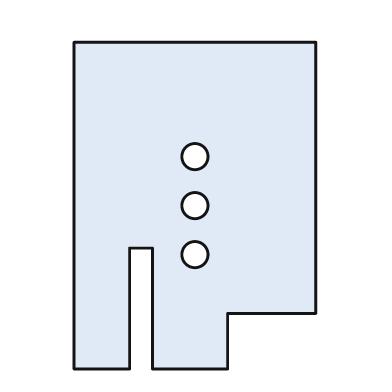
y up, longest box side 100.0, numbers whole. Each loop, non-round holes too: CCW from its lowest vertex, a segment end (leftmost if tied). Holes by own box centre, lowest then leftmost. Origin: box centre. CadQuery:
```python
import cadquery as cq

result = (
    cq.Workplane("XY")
    .moveTo(-37.0, -50.0)
    .lineTo(-20.0, -50.0)
    .lineTo(-20.0, -13.0)
    .lineTo(-13.0, -13.0)
    .lineTo(-13.0, -50.0)
    .lineTo(10.0, -50.0)
    .lineTo(10.0, -33.0)
    .lineTo(37.0, -33.0)
    .lineTo(37.0, 50.0)
    .lineTo(-37.0, 50.0)
    .close()
    .moveTo(0.0, -15.0)
    .circle(4.0)
    .moveTo(0.0, 0.0)
    .circle(4.0)
    .moveTo(0.0, 15.0)
    .circle(4.0)
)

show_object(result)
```